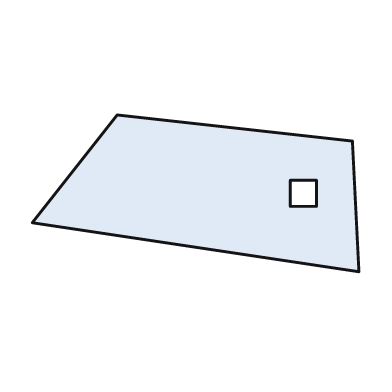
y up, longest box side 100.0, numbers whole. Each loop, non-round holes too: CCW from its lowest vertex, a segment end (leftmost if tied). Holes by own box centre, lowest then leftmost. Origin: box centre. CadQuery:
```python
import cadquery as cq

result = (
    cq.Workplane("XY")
    .moveTo(50.0, -24.0)
    .lineTo(48.0, 16.0)
    .lineTo(-24.0, 24.0)
    .lineTo(-50.0, -9.0)
    .close()
    .moveTo(29.0, -4.0)
    .lineTo(37.0, -4.0)
    .lineTo(37.0, 4.0)
    .lineTo(29.0, 4.0)
    .close()
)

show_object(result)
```